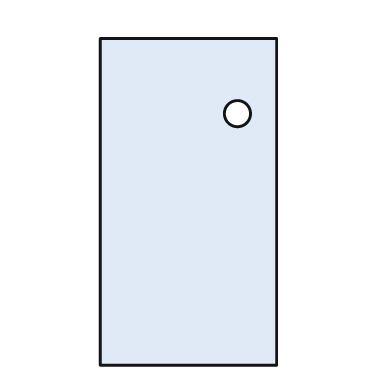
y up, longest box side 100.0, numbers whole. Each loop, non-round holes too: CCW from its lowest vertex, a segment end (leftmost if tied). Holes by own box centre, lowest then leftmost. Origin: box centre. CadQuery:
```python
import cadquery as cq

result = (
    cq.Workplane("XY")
    .moveTo(-27.0, -50.0)
    .lineTo(27.0, -50.0)
    .lineTo(27.0, 50.0)
    .lineTo(-27.0, 50.0)
    .close()
    .moveTo(15.0, 27.0)
    .circle(4.0)
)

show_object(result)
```